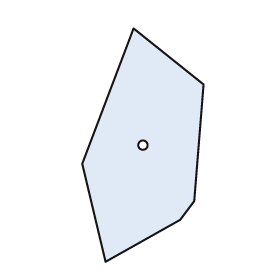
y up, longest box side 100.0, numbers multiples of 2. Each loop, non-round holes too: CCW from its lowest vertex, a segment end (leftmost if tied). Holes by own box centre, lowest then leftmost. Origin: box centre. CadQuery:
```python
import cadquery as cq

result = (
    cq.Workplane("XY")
    .moveTo(-16.0, -50.0)
    .lineTo(16.0, -32.0)
    .lineTo(22.0, -24.0)
    .lineTo(26.0, 26.0)
    .lineTo(-4.0, 50.0)
    .lineTo(-26.0, -8.0)
    .close()
    .moveTo(0.0, 0.0)
    .circle(2.0)
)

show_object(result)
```